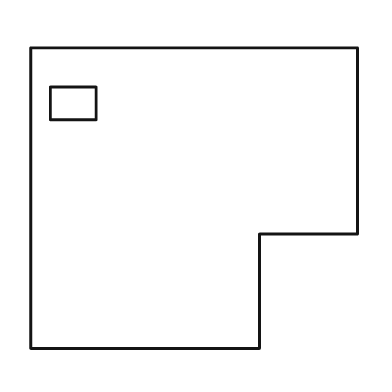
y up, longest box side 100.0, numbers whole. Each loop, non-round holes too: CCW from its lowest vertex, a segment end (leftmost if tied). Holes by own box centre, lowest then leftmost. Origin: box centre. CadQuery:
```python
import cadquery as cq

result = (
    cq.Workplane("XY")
    .moveTo(-50.0, -46.0)
    .lineTo(20.0, -46.0)
    .lineTo(20.0, -11.0)
    .lineTo(50.0, -11.0)
    .lineTo(50.0, 46.0)
    .lineTo(-50.0, 46.0)
    .close()
    .moveTo(-44.0, 24.0)
    .lineTo(-30.0, 24.0)
    .lineTo(-30.0, 34.0)
    .lineTo(-44.0, 34.0)
    .close()
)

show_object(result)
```